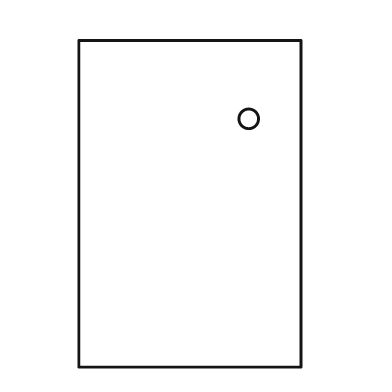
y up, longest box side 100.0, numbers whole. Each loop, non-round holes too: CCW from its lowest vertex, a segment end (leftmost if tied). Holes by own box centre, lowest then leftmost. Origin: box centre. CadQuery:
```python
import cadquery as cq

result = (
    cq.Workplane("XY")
    .moveTo(-34.0, -50.0)
    .lineTo(34.0, -50.0)
    .lineTo(34.0, 50.0)
    .lineTo(-34.0, 50.0)
    .close()
    .moveTo(18.0, 26.0)
    .circle(3.0)
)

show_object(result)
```